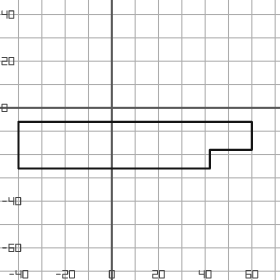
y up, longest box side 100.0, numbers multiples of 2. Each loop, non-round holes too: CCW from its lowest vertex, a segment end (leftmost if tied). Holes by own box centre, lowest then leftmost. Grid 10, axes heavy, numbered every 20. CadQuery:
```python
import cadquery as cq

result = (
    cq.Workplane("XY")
    .moveTo(-40.0, -26.0)
    .lineTo(42.0, -26.0)
    .lineTo(42.0, -18.0)
    .lineTo(60.0, -18.0)
    .lineTo(60.0, -6.0)
    .lineTo(-40.0, -6.0)
    .close()
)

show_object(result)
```